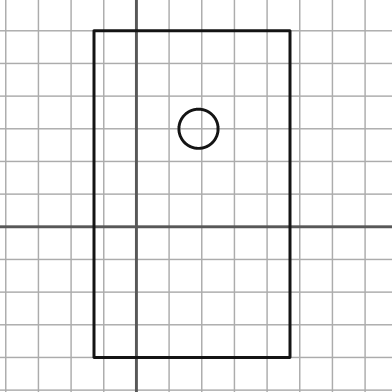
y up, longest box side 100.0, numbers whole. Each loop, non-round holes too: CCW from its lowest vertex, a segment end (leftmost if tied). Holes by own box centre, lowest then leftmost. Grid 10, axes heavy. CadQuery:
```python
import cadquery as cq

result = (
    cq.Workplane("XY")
    .moveTo(-13.0, -40.0)
    .lineTo(47.0, -40.0)
    .lineTo(47.0, 60.0)
    .lineTo(-13.0, 60.0)
    .close()
    .moveTo(19.0, 30.0)
    .circle(6.0)
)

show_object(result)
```